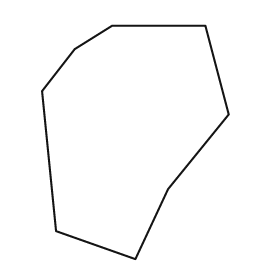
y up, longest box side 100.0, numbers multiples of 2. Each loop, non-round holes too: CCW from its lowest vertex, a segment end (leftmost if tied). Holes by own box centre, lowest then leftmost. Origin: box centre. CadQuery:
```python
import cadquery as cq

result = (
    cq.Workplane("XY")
    .moveTo(0.0, -50.0)
    .lineTo(14.0, -20.0)
    .lineTo(40.0, 12.0)
    .lineTo(30.0, 50.0)
    .lineTo(-10.0, 50.0)
    .lineTo(-26.0, 40.0)
    .lineTo(-40.0, 22.0)
    .lineTo(-34.0, -38.0)
    .close()
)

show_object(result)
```